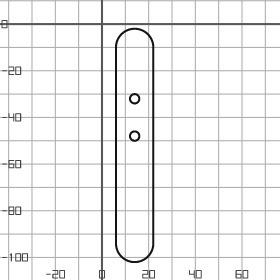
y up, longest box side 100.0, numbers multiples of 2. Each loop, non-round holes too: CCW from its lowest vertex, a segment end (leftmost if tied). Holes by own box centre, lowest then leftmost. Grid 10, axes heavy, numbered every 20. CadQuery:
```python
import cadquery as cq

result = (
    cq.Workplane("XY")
    .moveTo(6.0, -94.0)
    .threePointArc((14.0, -102.0), (22.0, -94.0))
    .lineTo(22.0, -10.0)
    .threePointArc((14.0, -2.0), (6.0, -10.0))
    .close()
    .moveTo(14.0, -48.0)
    .circle(2.0)
    .moveTo(14.0, -32.0)
    .circle(2.0)
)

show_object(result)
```